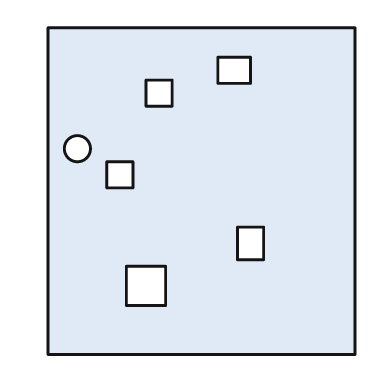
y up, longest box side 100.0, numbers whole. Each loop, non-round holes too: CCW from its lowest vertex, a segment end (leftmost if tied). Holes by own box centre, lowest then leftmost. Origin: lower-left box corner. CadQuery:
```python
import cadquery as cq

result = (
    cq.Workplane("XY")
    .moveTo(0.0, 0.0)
    .lineTo(94.0, 0.0)
    .lineTo(94.0, 100.0)
    .lineTo(0.0, 100.0)
    .close()
    .moveTo(24.0, 15.0)
    .lineTo(36.0, 15.0)
    .lineTo(36.0, 27.0)
    .lineTo(24.0, 27.0)
    .close()
    .moveTo(58.0, 29.0)
    .lineTo(66.0, 29.0)
    .lineTo(66.0, 39.0)
    .lineTo(58.0, 39.0)
    .close()
    .moveTo(18.0, 51.0)
    .lineTo(26.0, 51.0)
    .lineTo(26.0, 59.0)
    .lineTo(18.0, 59.0)
    .close()
    .moveTo(9.0, 63.0)
    .circle(4.0)
    .moveTo(30.0, 76.0)
    .lineTo(38.0, 76.0)
    .lineTo(38.0, 84.0)
    .lineTo(30.0, 84.0)
    .close()
    .moveTo(52.0, 83.0)
    .lineTo(62.0, 83.0)
    .lineTo(62.0, 91.0)
    .lineTo(52.0, 91.0)
    .close()
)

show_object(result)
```